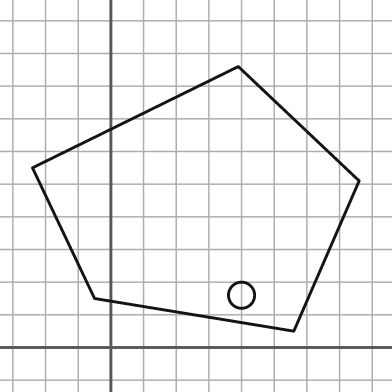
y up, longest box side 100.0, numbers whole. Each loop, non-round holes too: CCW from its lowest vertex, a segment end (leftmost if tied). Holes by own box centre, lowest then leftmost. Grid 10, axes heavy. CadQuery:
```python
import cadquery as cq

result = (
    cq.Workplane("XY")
    .moveTo(56.0, 5.0)
    .lineTo(76.0, 51.0)
    .lineTo(39.0, 86.0)
    .lineTo(-24.0, 55.0)
    .lineTo(-5.0, 15.0)
    .close()
    .moveTo(40.0, 16.0)
    .circle(4.0)
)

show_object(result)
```